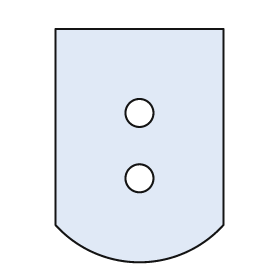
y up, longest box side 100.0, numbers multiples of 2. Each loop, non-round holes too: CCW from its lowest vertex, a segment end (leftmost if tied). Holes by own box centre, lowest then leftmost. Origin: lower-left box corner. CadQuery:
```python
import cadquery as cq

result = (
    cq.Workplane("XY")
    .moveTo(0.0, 16.0)
    .threePointArc((36.0, 0.0), (72.0, 16.0))
    .lineTo(72.0, 100.0)
    .lineTo(0.0, 100.0)
    .close()
    .moveTo(36.0, 36.0)
    .circle(6.0)
    .moveTo(36.0, 64.0)
    .circle(6.0)
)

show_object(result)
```